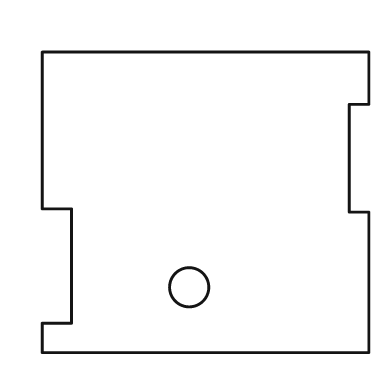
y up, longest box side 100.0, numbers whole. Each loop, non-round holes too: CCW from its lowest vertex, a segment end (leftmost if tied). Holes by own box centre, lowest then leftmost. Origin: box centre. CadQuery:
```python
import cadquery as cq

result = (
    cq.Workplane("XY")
    .moveTo(-50.0, -46.0)
    .lineTo(50.0, -46.0)
    .lineTo(50.0, -3.0)
    .lineTo(44.0, -3.0)
    .lineTo(44.0, 30.0)
    .lineTo(50.0, 30.0)
    .lineTo(50.0, 46.0)
    .lineTo(-50.0, 46.0)
    .lineTo(-50.0, -2.0)
    .lineTo(-41.0, -2.0)
    .lineTo(-41.0, -37.0)
    .lineTo(-50.0, -37.0)
    .close()
    .moveTo(-5.0, -26.0)
    .circle(6.0)
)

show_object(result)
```